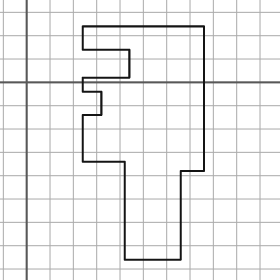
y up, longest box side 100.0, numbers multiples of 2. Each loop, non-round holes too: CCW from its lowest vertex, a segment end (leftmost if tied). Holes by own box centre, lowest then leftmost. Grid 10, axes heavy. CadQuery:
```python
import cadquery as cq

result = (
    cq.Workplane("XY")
    .moveTo(42.0, -76.0)
    .lineTo(66.0, -76.0)
    .lineTo(66.0, -38.0)
    .lineTo(76.0, -38.0)
    .lineTo(76.0, 24.0)
    .lineTo(24.0, 24.0)
    .lineTo(24.0, 14.0)
    .lineTo(44.0, 14.0)
    .lineTo(44.0, 2.0)
    .lineTo(24.0, 2.0)
    .lineTo(24.0, -4.0)
    .lineTo(32.0, -4.0)
    .lineTo(32.0, -14.0)
    .lineTo(24.0, -14.0)
    .lineTo(24.0, -34.0)
    .lineTo(42.0, -34.0)
    .close()
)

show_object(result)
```